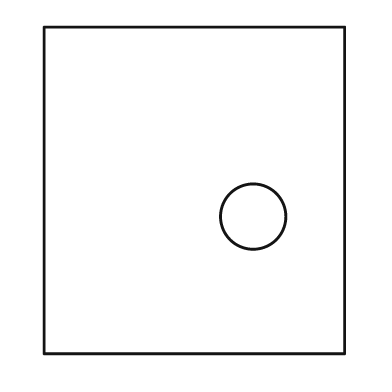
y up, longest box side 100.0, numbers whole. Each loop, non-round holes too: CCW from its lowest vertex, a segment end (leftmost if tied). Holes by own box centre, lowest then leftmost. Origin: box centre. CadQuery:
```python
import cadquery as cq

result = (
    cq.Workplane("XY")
    .moveTo(-46.0, -50.0)
    .lineTo(46.0, -50.0)
    .lineTo(46.0, 50.0)
    .lineTo(-46.0, 50.0)
    .close()
    .moveTo(18.0, -8.0)
    .circle(10.0)
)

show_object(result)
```